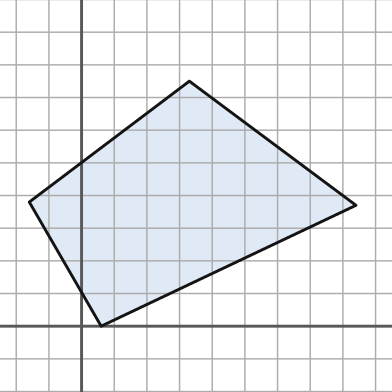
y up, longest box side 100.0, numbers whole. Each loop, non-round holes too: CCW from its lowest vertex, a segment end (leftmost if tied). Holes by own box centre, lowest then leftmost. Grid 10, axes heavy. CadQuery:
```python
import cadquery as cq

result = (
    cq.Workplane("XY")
    .moveTo(6.0, 0.0)
    .lineTo(84.0, 37.0)
    .lineTo(33.0, 75.0)
    .lineTo(-16.0, 38.0)
    .close()
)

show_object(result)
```